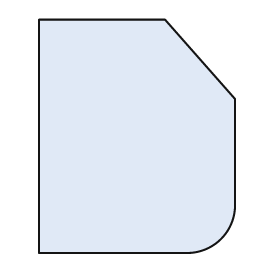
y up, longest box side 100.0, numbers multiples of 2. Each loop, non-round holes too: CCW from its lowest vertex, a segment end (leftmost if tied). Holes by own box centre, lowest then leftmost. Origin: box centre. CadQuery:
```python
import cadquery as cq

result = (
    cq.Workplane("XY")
    .moveTo(-42.0, -50.0)
    .lineTo(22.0, -50.0)
    .threePointArc((36.0, -44.0), (42.0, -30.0))
    .lineTo(42.0, 16.0)
    .lineTo(12.0, 50.0)
    .lineTo(-42.0, 50.0)
    .close()
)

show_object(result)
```